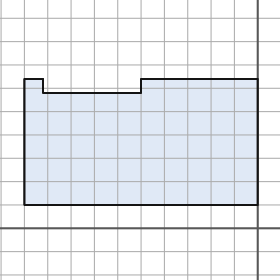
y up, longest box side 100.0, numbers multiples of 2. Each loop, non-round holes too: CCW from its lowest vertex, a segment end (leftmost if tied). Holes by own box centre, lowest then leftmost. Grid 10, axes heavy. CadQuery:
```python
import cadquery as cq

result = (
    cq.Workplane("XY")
    .moveTo(-100.0, 10.0)
    .lineTo(0.0, 10.0)
    .lineTo(0.0, 64.0)
    .lineTo(-50.0, 64.0)
    .lineTo(-50.0, 58.0)
    .lineTo(-92.0, 58.0)
    .lineTo(-92.0, 64.0)
    .lineTo(-100.0, 64.0)
    .close()
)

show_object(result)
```